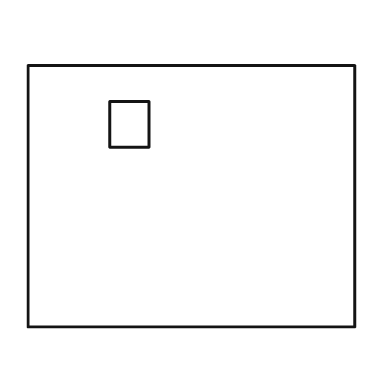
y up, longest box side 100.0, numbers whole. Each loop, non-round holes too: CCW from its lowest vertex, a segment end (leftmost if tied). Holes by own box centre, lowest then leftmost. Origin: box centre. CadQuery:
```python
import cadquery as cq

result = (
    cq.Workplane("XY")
    .moveTo(-50.0, -40.0)
    .lineTo(50.0, -40.0)
    .lineTo(50.0, 40.0)
    .lineTo(-50.0, 40.0)
    .close()
    .moveTo(-25.0, 15.0)
    .lineTo(-13.0, 15.0)
    .lineTo(-13.0, 29.0)
    .lineTo(-25.0, 29.0)
    .close()
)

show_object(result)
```